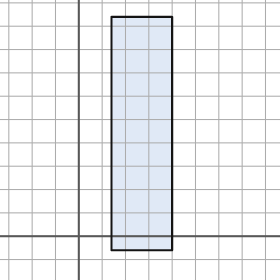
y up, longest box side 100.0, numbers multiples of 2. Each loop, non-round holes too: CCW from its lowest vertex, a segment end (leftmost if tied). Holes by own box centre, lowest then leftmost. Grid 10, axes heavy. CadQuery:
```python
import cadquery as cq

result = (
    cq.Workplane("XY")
    .moveTo(14.0, -6.0)
    .lineTo(40.0, -6.0)
    .lineTo(40.0, 94.0)
    .lineTo(14.0, 94.0)
    .close()
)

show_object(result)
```